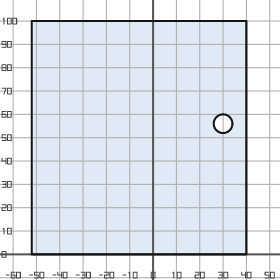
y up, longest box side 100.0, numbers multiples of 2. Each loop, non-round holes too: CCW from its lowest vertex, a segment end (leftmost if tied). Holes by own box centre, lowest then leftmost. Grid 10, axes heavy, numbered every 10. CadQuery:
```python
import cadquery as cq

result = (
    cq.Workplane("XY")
    .moveTo(-52.0, 0.0)
    .lineTo(40.0, 0.0)
    .lineTo(40.0, 100.0)
    .lineTo(-52.0, 100.0)
    .close()
    .moveTo(30.0, 56.0)
    .circle(4.0)
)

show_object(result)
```